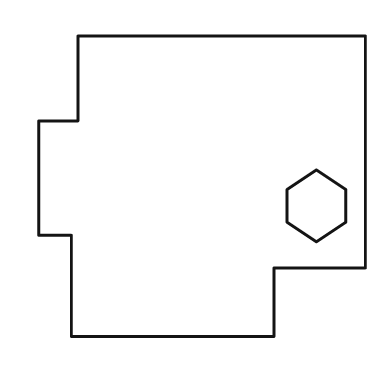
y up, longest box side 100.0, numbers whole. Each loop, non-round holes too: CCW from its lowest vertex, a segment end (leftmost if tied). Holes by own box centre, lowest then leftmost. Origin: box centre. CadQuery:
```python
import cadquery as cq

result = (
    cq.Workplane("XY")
    .moveTo(-40.0, -46.0)
    .lineTo(22.0, -46.0)
    .lineTo(22.0, -25.0)
    .lineTo(50.0, -25.0)
    .lineTo(50.0, 46.0)
    .lineTo(-38.0, 46.0)
    .lineTo(-38.0, 20.0)
    .lineTo(-50.0, 20.0)
    .lineTo(-50.0, -15.0)
    .lineTo(-40.0, -15.0)
    .close()
    .moveTo(35.0, -17.0)
    .lineTo(44.0, -11.0)
    .lineTo(44.0, -1.0)
    .lineTo(35.0, 5.0)
    .lineTo(26.0, -1.0)
    .lineTo(26.0, -11.0)
    .close()
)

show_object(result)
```